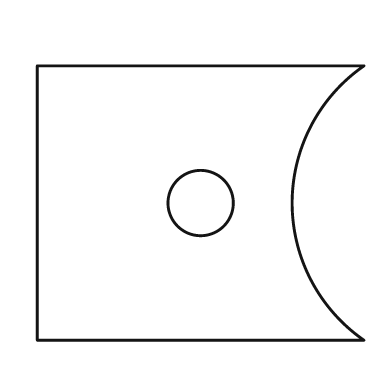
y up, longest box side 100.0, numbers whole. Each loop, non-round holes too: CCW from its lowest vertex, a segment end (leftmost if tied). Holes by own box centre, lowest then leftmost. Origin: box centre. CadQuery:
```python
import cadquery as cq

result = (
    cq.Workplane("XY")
    .moveTo(-50.0, -42.0)
    .lineTo(50.0, -42.0)
    .threePointArc((28.0, 0.0), (50.0, 42.0))
    .lineTo(-50.0, 42.0)
    .close()
    .moveTo(0.0, 0.0)
    .circle(10.0)
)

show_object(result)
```